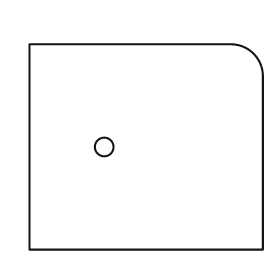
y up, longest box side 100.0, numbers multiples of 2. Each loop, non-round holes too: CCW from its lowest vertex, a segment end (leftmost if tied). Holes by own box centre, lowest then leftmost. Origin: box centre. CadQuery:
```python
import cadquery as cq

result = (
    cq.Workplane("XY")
    .moveTo(-50.0, -44.0)
    .lineTo(50.0, -44.0)
    .lineTo(50.0, 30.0)
    .threePointArc((46.0, 40.0), (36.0, 44.0))
    .lineTo(-50.0, 44.0)
    .close()
    .moveTo(-18.0, 0.0)
    .circle(4.0)
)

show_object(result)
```